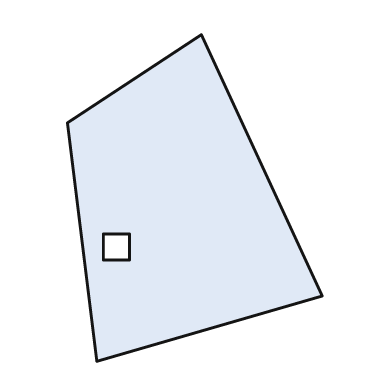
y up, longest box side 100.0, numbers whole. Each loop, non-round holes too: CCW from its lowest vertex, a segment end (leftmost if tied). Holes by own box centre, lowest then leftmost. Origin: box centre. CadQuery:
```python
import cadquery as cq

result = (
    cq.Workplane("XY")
    .moveTo(-30.0, -50.0)
    .lineTo(39.0, -30.0)
    .lineTo(2.0, 50.0)
    .lineTo(-39.0, 23.0)
    .close()
    .moveTo(-28.0, -19.0)
    .lineTo(-20.0, -19.0)
    .lineTo(-20.0, -11.0)
    .lineTo(-28.0, -11.0)
    .close()
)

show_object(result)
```